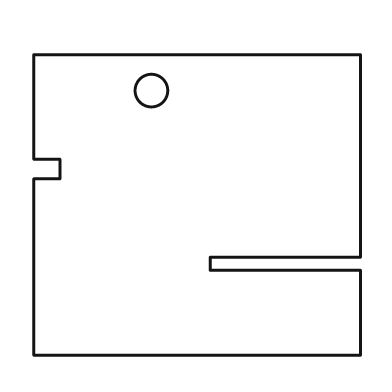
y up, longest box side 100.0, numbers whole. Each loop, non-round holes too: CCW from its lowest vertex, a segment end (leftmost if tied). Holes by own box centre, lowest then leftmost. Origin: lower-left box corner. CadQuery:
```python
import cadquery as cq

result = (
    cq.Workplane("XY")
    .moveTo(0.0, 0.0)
    .lineTo(100.0, 0.0)
    .lineTo(100.0, 26.0)
    .lineTo(54.0, 26.0)
    .lineTo(54.0, 30.0)
    .lineTo(100.0, 30.0)
    .lineTo(100.0, 92.0)
    .lineTo(0.0, 92.0)
    .lineTo(0.0, 60.0)
    .lineTo(8.0, 60.0)
    .lineTo(8.0, 54.0)
    .lineTo(0.0, 54.0)
    .close()
    .moveTo(36.0, 81.0)
    .circle(5.0)
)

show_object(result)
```